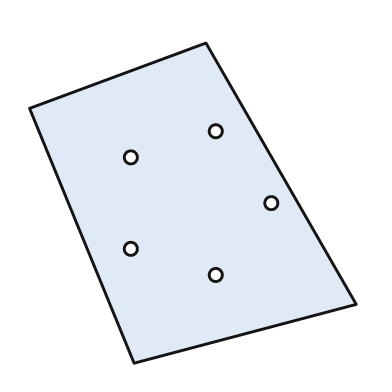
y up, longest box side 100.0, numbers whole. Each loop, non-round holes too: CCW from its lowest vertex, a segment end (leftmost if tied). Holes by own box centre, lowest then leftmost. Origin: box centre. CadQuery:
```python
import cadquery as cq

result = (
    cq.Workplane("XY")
    .moveTo(-18.0, -49.0)
    .lineTo(50.0, -31.0)
    .lineTo(4.0, 49.0)
    .lineTo(-50.0, 29.0)
    .close()
    .moveTo(7.0, -22.0)
    .circle(2.0)
    .moveTo(-19.0, -14.0)
    .circle(2.0)
    .moveTo(24.0, 0.0)
    .circle(2.0)
    .moveTo(-19.0, 14.0)
    .circle(2.0)
    .moveTo(7.0, 22.0)
    .circle(2.0)
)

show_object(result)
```